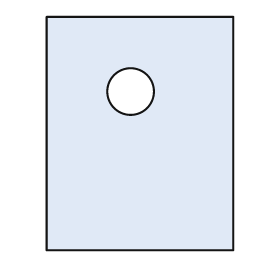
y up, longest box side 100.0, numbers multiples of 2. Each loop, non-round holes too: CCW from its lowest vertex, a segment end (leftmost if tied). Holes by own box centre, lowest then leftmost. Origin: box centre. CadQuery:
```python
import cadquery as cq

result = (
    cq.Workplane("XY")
    .moveTo(-40.0, -50.0)
    .lineTo(40.0, -50.0)
    .lineTo(40.0, 50.0)
    .lineTo(-40.0, 50.0)
    .close()
    .moveTo(-4.0, 18.0)
    .circle(10.0)
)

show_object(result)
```